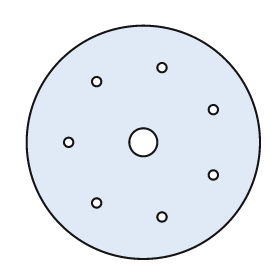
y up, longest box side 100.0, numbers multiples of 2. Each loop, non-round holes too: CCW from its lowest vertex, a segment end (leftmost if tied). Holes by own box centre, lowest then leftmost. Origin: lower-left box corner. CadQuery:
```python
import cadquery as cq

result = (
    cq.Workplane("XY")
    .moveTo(50.0, 50.0)
    .circle(50.0)
    .moveTo(58.0, 18.0)
    .circle(2.0)
    .moveTo(30.0, 24.0)
    .circle(2.0)
    .moveTo(80.0, 36.0)
    .circle(2.0)
    .moveTo(18.0, 50.0)
    .circle(2.0)
    .moveTo(50.0, 50.0)
    .circle(6.0)
    .moveTo(80.0, 64.0)
    .circle(2.0)
    .moveTo(30.0, 76.0)
    .circle(2.0)
    .moveTo(58.0, 82.0)
    .circle(2.0)
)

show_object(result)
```